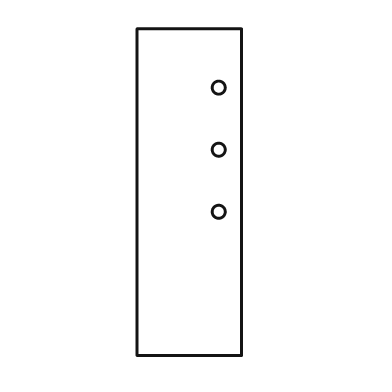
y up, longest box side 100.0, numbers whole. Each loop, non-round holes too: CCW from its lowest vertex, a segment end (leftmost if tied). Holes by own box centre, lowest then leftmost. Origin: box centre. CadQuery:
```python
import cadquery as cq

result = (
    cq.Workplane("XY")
    .moveTo(-16.0, -50.0)
    .lineTo(16.0, -50.0)
    .lineTo(16.0, 50.0)
    .lineTo(-16.0, 50.0)
    .close()
    .moveTo(9.0, -6.0)
    .circle(2.0)
    .moveTo(9.0, 13.0)
    .circle(2.0)
    .moveTo(9.0, 32.0)
    .circle(2.0)
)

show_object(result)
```